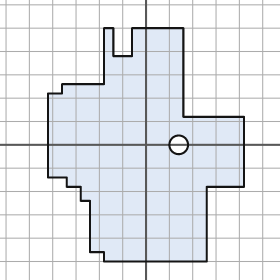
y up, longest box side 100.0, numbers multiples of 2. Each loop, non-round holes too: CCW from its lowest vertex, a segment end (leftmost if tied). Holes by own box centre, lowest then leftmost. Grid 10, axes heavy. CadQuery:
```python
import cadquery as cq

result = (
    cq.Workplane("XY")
    .moveTo(-18.0, -50.0)
    .lineTo(26.0, -50.0)
    .lineTo(26.0, -18.0)
    .lineTo(42.0, -18.0)
    .lineTo(42.0, 12.0)
    .lineTo(16.0, 12.0)
    .lineTo(16.0, 50.0)
    .lineTo(-6.0, 50.0)
    .lineTo(-6.0, 38.0)
    .lineTo(-14.0, 38.0)
    .lineTo(-14.0, 50.0)
    .lineTo(-18.0, 50.0)
    .lineTo(-18.0, 26.0)
    .lineTo(-36.0, 26.0)
    .lineTo(-36.0, 22.0)
    .lineTo(-42.0, 22.0)
    .lineTo(-42.0, -14.0)
    .lineTo(-34.0, -14.0)
    .lineTo(-34.0, -18.0)
    .lineTo(-28.0, -18.0)
    .lineTo(-28.0, -24.0)
    .lineTo(-24.0, -24.0)
    .lineTo(-24.0, -46.0)
    .lineTo(-18.0, -46.0)
    .close()
    .moveTo(14.0, 0.0)
    .circle(4.0)
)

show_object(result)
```